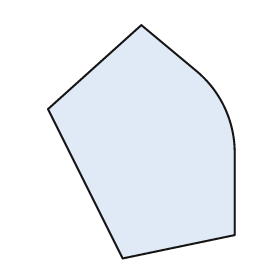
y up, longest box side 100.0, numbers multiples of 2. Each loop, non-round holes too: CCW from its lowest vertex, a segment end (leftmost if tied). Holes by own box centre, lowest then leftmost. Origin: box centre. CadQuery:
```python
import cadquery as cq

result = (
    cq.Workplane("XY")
    .moveTo(-8.0, -50.0)
    .lineTo(40.0, -40.0)
    .lineTo(40.0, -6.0)
    .threePointArc((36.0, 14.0), (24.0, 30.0))
    .lineTo(0.0, 50.0)
    .lineTo(-40.0, 14.0)
    .close()
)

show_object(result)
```